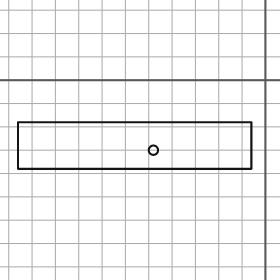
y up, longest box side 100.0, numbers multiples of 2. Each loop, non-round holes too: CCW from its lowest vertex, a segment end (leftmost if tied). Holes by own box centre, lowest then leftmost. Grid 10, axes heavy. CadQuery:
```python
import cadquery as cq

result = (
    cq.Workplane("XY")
    .moveTo(-106.0, -38.0)
    .lineTo(-6.0, -38.0)
    .lineTo(-6.0, -18.0)
    .lineTo(-106.0, -18.0)
    .close()
    .moveTo(-48.0, -30.0)
    .circle(2.0)
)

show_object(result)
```